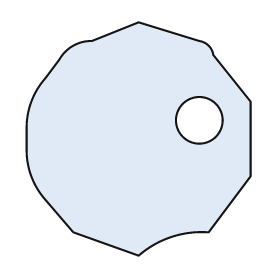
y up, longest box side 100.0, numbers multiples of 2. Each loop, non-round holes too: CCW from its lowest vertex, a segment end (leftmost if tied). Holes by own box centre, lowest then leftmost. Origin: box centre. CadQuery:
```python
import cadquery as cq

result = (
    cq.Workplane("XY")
    .moveTo(0.0, -50.0)
    .threePointArc((14.0, -42.0), (30.0, -40.0))
    .lineTo(48.0, -16.0)
    .lineTo(48.0, 16.0)
    .lineTo(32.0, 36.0)
    .threePointArc((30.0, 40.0), (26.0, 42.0))
    .lineTo(0.0, 50.0)
    .lineTo(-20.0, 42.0)
    .threePointArc((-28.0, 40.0), (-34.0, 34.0))
    .lineTo(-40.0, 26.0)
    .threePointArc((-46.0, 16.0), (-48.0, 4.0))
    .lineTo(-48.0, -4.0)
    .threePointArc((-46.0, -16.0), (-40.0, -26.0))
    .lineTo(-28.0, -40.0)
    .close()
    .moveTo(26.0, 8.0)
    .circle(10.0)
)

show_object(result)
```